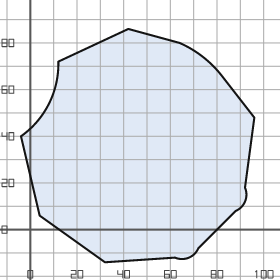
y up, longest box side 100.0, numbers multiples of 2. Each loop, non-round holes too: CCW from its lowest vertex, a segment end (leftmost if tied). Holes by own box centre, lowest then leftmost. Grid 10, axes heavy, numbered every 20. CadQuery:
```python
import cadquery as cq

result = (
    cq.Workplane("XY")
    .moveTo(32.0, -14.0)
    .lineTo(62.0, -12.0)
    .threePointArc((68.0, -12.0), (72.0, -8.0))
    .lineTo(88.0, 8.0)
    .threePointArc((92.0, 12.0), (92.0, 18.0))
    .lineTo(96.0, 48.0)
    .lineTo(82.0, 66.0)
    .threePointArc((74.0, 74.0), (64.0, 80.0))
    .lineTo(42.0, 86.0)
    .lineTo(12.0, 72.0)
    .threePointArc((8.0, 54.0), (-4.0, 40.0))
    .lineTo(4.0, 6.0)
    .close()
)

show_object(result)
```